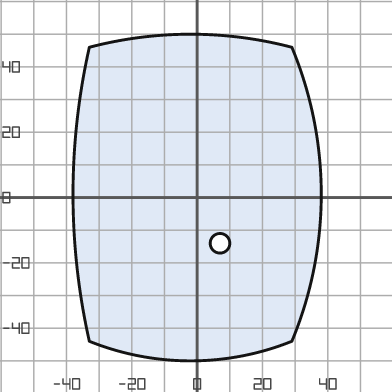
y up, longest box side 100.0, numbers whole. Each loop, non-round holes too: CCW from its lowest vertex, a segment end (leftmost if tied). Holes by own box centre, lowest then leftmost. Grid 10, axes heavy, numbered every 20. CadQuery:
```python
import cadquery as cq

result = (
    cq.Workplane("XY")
    .moveTo(-33.0, -44.0)
    .threePointArc((-2.0, -50.0), (29.0, -44.0))
    .threePointArc((38.0, 1.0), (29.0, 46.0))
    .threePointArc((-2.0, 50.0), (-33.0, 46.0))
    .threePointArc((-38.0, 1.0), (-33.0, -44.0))
    .close()
    .moveTo(7.0, -14.0)
    .circle(3.0)
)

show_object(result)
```